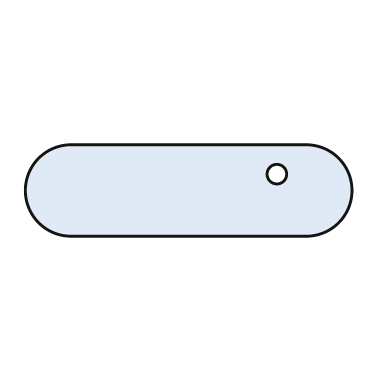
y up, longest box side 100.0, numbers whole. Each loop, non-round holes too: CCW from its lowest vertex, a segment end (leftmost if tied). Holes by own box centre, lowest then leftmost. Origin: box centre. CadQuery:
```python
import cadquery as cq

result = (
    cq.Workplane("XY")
    .moveTo(-36.0, -14.0)
    .lineTo(36.0, -14.0)
    .threePointArc((50.0, 0.0), (36.0, 14.0))
    .lineTo(-36.0, 14.0)
    .threePointArc((-50.0, 0.0), (-36.0, -14.0))
    .close()
    .moveTo(27.0, 5.0)
    .circle(3.0)
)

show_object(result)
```